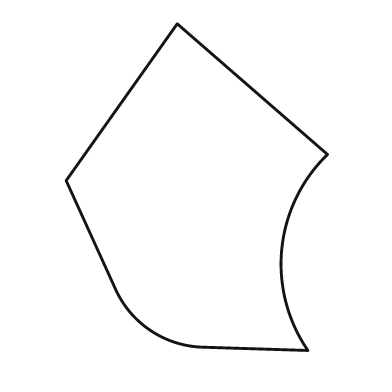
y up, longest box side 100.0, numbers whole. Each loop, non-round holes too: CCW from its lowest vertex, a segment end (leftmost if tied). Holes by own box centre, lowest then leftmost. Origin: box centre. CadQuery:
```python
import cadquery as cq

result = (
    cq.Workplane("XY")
    .moveTo(34.0, -50.0)
    .threePointArc((26.0, -19.0), (40.0, 10.0))
    .lineTo(-6.0, 50.0)
    .lineTo(-40.0, 2.0)
    .lineTo(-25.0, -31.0)
    .threePointArc((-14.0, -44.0), (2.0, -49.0))
    .close()
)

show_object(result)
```